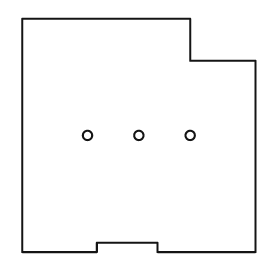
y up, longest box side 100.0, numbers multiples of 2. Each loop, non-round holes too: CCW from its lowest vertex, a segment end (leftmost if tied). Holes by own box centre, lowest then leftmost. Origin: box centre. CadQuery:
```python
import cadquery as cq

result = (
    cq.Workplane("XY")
    .moveTo(-50.0, -50.0)
    .lineTo(-18.0, -50.0)
    .lineTo(-18.0, -46.0)
    .lineTo(8.0, -46.0)
    .lineTo(8.0, -50.0)
    .lineTo(50.0, -50.0)
    .lineTo(50.0, 32.0)
    .lineTo(22.0, 32.0)
    .lineTo(22.0, 50.0)
    .lineTo(-50.0, 50.0)
    .close()
    .moveTo(-22.0, 0.0)
    .circle(2.0)
    .moveTo(0.0, 0.0)
    .circle(2.0)
    .moveTo(22.0, 0.0)
    .circle(2.0)
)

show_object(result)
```